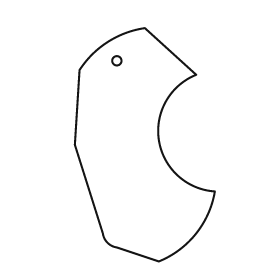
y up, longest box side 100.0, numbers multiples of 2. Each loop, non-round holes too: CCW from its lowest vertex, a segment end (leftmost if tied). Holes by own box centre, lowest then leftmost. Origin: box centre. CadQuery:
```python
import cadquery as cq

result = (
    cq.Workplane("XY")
    .moveTo(6.0, -50.0)
    .threePointArc((22.0, -38.0), (30.0, -20.0))
    .threePointArc((6.0, 2.0), (22.0, 30.0))
    .lineTo(0.0, 50.0)
    .threePointArc((-16.0, 44.0), (-28.0, 32.0))
    .lineTo(-30.0, 0.0)
    .lineTo(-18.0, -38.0)
    .threePointArc((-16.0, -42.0), (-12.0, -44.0))
    .close()
    .moveTo(-12.0, 36.0)
    .circle(2.0)
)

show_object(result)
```